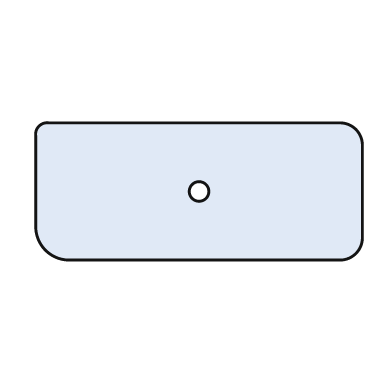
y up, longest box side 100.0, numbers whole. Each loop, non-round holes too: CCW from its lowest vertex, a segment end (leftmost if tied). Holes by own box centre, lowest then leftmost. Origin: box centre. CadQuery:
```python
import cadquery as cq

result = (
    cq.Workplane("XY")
    .moveTo(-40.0, -21.0)
    .lineTo(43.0, -21.0)
    .threePointArc((48.0, -19.0), (50.0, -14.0))
    .lineTo(50.0, 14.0)
    .threePointArc((48.0, 19.0), (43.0, 21.0))
    .lineTo(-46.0, 21.0)
    .threePointArc((-49.0, 20.0), (-50.0, 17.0))
    .lineTo(-50.0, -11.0)
    .threePointArc((-47.0, -18.0), (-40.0, -21.0))
    .close()
    .moveTo(0.0, 0.0)
    .circle(3.0)
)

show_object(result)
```